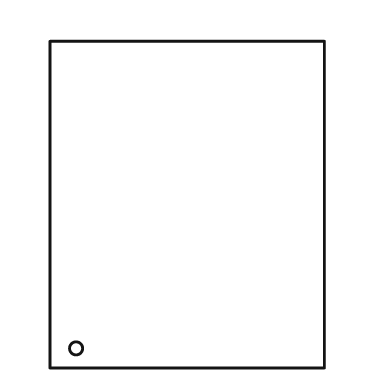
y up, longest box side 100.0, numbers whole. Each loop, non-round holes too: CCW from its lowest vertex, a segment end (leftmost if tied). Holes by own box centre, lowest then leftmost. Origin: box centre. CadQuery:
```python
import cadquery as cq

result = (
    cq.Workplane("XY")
    .moveTo(-42.0, -50.0)
    .lineTo(42.0, -50.0)
    .lineTo(42.0, 50.0)
    .lineTo(-42.0, 50.0)
    .close()
    .moveTo(-34.0, -44.0)
    .circle(2.0)
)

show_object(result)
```